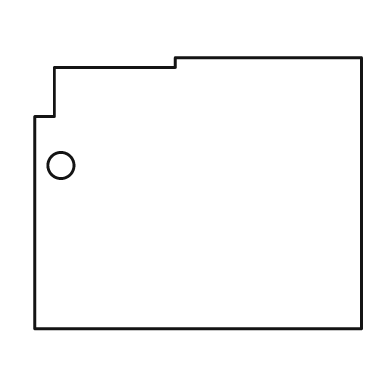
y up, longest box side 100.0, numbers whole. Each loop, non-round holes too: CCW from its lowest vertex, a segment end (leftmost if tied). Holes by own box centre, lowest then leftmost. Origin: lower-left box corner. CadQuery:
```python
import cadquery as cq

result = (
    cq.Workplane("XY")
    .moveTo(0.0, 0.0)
    .lineTo(100.0, 0.0)
    .lineTo(100.0, 83.0)
    .lineTo(43.0, 83.0)
    .lineTo(43.0, 80.0)
    .lineTo(6.0, 80.0)
    .lineTo(6.0, 65.0)
    .lineTo(0.0, 65.0)
    .close()
    .moveTo(8.0, 50.0)
    .circle(4.0)
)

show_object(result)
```